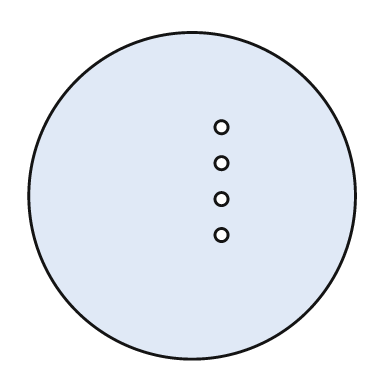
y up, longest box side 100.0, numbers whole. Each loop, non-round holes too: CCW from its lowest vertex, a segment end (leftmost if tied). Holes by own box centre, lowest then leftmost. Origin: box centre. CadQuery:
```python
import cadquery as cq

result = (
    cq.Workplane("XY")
    .moveTo(0.0, 0.0)
    .circle(50.0)
    .moveTo(9.0, -12.0)
    .circle(2.0)
    .moveTo(9.0, -1.0)
    .circle(2.0)
    .moveTo(9.0, 10.0)
    .circle(2.0)
    .moveTo(9.0, 21.0)
    .circle(2.0)
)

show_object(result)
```